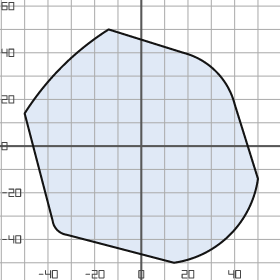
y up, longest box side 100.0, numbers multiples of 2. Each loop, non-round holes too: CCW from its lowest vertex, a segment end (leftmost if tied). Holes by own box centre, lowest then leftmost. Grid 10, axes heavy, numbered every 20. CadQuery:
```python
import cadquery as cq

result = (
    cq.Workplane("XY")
    .moveTo(14.0, -50.0)
    .threePointArc((38.0, -38.0), (50.0, -14.0))
    .lineTo(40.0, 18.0)
    .threePointArc((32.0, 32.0), (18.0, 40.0))
    .lineTo(-14.0, 50.0)
    .threePointArc((-34.0, 34.0), (-50.0, 14.0))
    .lineTo(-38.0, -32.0)
    .threePointArc((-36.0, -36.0), (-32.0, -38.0))
    .close()
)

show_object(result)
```